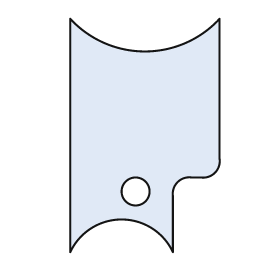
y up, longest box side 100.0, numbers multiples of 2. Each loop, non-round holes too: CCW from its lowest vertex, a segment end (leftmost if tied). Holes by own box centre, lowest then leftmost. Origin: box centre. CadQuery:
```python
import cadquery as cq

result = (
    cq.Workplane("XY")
    .moveTo(-32.0, -50.0)
    .threePointArc((-10.0, -36.0), (12.0, -50.0))
    .lineTo(12.0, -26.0)
    .threePointArc((14.0, -20.0), (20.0, -18.0))
    .lineTo(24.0, -18.0)
    .threePointArc((30.0, -16.0), (32.0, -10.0))
    .lineTo(32.0, 50.0)
    .threePointArc((0.0, 36.0), (-32.0, 50.0))
    .close()
    .moveTo(-4.0, -24.0)
    .circle(6.0)
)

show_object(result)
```